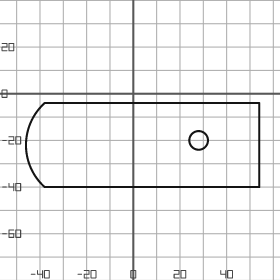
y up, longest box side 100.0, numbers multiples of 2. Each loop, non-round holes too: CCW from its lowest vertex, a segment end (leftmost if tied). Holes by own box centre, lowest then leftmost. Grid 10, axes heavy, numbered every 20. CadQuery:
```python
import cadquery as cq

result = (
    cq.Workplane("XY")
    .moveTo(-38.0, -40.0)
    .lineTo(54.0, -40.0)
    .lineTo(54.0, -4.0)
    .lineTo(-38.0, -4.0)
    .threePointArc((-46.0, -22.0), (-38.0, -40.0))
    .close()
    .moveTo(28.0, -20.0)
    .circle(4.0)
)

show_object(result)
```